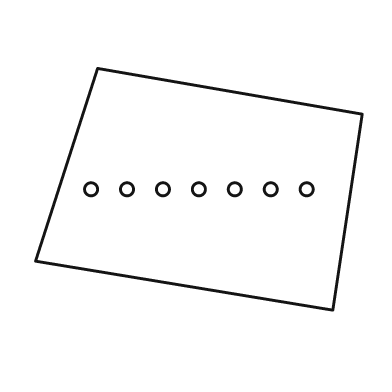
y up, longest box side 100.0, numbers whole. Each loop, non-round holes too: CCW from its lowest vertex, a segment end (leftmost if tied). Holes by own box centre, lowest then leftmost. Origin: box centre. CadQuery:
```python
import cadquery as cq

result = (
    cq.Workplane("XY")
    .moveTo(41.0, -37.0)
    .lineTo(50.0, 23.0)
    .lineTo(-31.0, 37.0)
    .lineTo(-50.0, -22.0)
    .close()
    .moveTo(-33.0, 0.0)
    .circle(2.0)
    .moveTo(-22.0, 0.0)
    .circle(2.0)
    .moveTo(-11.0, 0.0)
    .circle(2.0)
    .moveTo(0.0, 0.0)
    .circle(2.0)
    .moveTo(11.0, 0.0)
    .circle(2.0)
    .moveTo(22.0, 0.0)
    .circle(2.0)
    .moveTo(33.0, 0.0)
    .circle(2.0)
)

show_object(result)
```